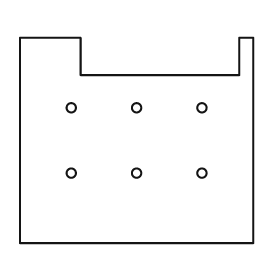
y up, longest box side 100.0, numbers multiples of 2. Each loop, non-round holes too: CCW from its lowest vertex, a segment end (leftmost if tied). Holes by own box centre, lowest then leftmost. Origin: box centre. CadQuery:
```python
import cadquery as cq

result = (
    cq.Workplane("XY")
    .moveTo(-50.0, -44.0)
    .lineTo(50.0, -44.0)
    .lineTo(50.0, 44.0)
    .lineTo(44.0, 44.0)
    .lineTo(44.0, 28.0)
    .lineTo(-24.0, 28.0)
    .lineTo(-24.0, 44.0)
    .lineTo(-50.0, 44.0)
    .close()
    .moveTo(-28.0, -14.0)
    .circle(2.0)
    .moveTo(0.0, -14.0)
    .circle(2.0)
    .moveTo(28.0, -14.0)
    .circle(2.0)
    .moveTo(-28.0, 14.0)
    .circle(2.0)
    .moveTo(0.0, 14.0)
    .circle(2.0)
    .moveTo(28.0, 14.0)
    .circle(2.0)
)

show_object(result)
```